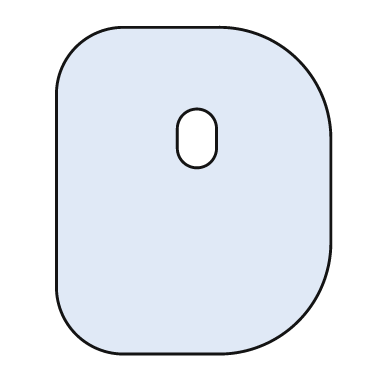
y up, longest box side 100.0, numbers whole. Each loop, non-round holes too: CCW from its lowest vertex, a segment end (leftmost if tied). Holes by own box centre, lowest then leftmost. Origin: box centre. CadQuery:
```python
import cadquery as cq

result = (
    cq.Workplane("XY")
    .moveTo(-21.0, -50.0)
    .lineTo(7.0, -50.0)
    .threePointArc((32.0, -40.0), (42.0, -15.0))
    .lineTo(42.0, 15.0)
    .threePointArc((32.0, 40.0), (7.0, 50.0))
    .lineTo(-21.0, 50.0)
    .threePointArc((-36.0, 44.0), (-42.0, 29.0))
    .lineTo(-42.0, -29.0)
    .threePointArc((-36.0, -44.0), (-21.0, -50.0))
    .close()
    .moveTo(-5.0, 13.0)
    .threePointArc((1.0, 7.0), (7.0, 13.0))
    .lineTo(7.0, 19.0)
    .threePointArc((1.0, 25.0), (-5.0, 19.0))
    .close()
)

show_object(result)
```